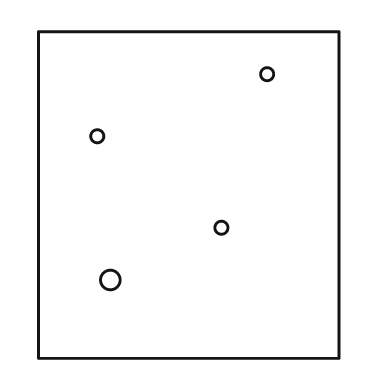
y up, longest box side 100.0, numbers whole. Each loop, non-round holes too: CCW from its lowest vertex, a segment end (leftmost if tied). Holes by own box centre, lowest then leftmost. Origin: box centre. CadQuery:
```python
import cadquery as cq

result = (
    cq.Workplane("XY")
    .moveTo(-46.0, -50.0)
    .lineTo(46.0, -50.0)
    .lineTo(46.0, 50.0)
    .lineTo(-46.0, 50.0)
    .close()
    .moveTo(-24.0, -26.0)
    .circle(3.0)
    .moveTo(10.0, -10.0)
    .circle(2.0)
    .moveTo(-28.0, 18.0)
    .circle(2.0)
    .moveTo(24.0, 37.0)
    .circle(2.0)
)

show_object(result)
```